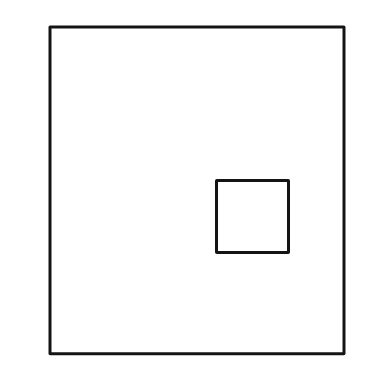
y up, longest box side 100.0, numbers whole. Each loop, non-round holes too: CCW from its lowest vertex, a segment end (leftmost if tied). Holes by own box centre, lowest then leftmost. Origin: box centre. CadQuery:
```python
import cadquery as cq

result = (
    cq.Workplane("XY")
    .moveTo(-45.0, -50.0)
    .lineTo(45.0, -50.0)
    .lineTo(45.0, 50.0)
    .lineTo(-45.0, 50.0)
    .close()
    .moveTo(6.0, -19.0)
    .lineTo(28.0, -19.0)
    .lineTo(28.0, 3.0)
    .lineTo(6.0, 3.0)
    .close()
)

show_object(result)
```